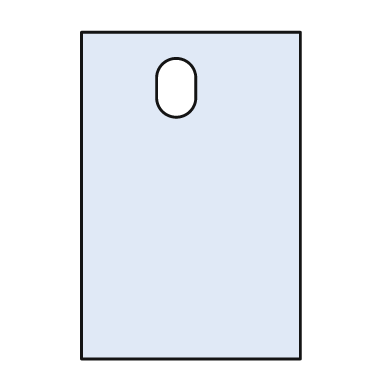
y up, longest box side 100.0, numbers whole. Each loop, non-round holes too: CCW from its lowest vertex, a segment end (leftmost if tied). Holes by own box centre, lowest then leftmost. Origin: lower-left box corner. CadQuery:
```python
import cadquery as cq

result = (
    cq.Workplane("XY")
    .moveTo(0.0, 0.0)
    .lineTo(67.0, 0.0)
    .lineTo(67.0, 100.0)
    .lineTo(0.0, 100.0)
    .close()
    .moveTo(23.0, 80.0)
    .threePointArc((29.0, 74.0), (35.0, 80.0))
    .lineTo(35.0, 86.0)
    .threePointArc((29.0, 92.0), (23.0, 86.0))
    .close()
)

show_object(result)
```